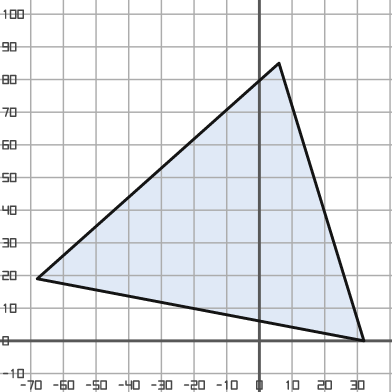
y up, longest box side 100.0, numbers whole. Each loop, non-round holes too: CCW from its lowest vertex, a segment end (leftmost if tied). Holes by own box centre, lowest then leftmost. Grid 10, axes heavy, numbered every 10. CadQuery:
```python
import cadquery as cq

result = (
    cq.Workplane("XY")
    .moveTo(32.0, 0.0)
    .lineTo(6.0, 85.0)
    .lineTo(-68.0, 19.0)
    .close()
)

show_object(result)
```